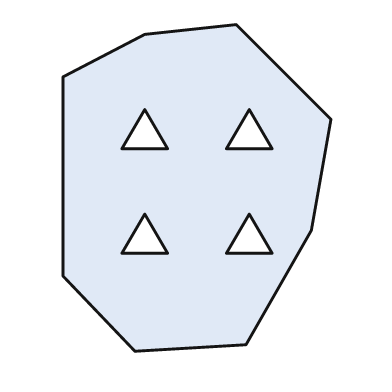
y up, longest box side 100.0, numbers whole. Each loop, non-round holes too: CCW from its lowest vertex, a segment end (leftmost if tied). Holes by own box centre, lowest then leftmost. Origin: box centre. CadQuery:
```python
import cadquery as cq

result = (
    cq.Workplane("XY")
    .moveTo(-19.0, -50.0)
    .lineTo(15.0, -48.0)
    .lineTo(35.0, -13.0)
    .lineTo(41.0, 21.0)
    .lineTo(12.0, 50.0)
    .lineTo(-16.0, 47.0)
    .lineTo(-41.0, 34.0)
    .lineTo(-41.0, -27.0)
    .close()
    .moveTo(-23.0, -20.0)
    .lineTo(-9.0, -20.0)
    .lineTo(-16.0, -8.0)
    .close()
    .moveTo(9.0, -20.0)
    .lineTo(23.0, -20.0)
    .lineTo(16.0, -8.0)
    .close()
    .moveTo(-23.0, 12.0)
    .lineTo(-9.0, 12.0)
    .lineTo(-16.0, 24.0)
    .close()
    .moveTo(9.0, 12.0)
    .lineTo(23.0, 12.0)
    .lineTo(16.0, 24.0)
    .close()
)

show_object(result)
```